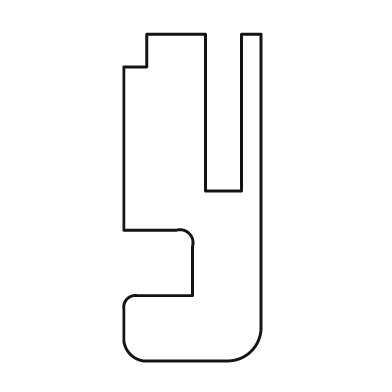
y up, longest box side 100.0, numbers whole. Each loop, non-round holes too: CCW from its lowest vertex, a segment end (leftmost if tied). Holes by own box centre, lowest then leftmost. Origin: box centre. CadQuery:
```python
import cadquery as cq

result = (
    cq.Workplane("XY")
    .moveTo(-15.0, -50.0)
    .lineTo(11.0, -50.0)
    .threePointArc((18.0, -47.0), (21.0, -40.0))
    .lineTo(21.0, 50.0)
    .lineTo(15.0, 50.0)
    .lineTo(15.0, 2.0)
    .lineTo(4.0, 2.0)
    .lineTo(4.0, 50.0)
    .lineTo(-14.0, 50.0)
    .lineTo(-14.0, 40.0)
    .lineTo(-21.0, 40.0)
    .lineTo(-21.0, -10.0)
    .lineTo(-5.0, -10.0)
    .threePointArc((-1.0, -11.0), (0.0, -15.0))
    .lineTo(0.0, -30.0)
    .lineTo(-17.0, -30.0)
    .threePointArc((-20.0, -31.0), (-21.0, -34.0))
    .lineTo(-21.0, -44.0)
    .threePointArc((-19.0, -48.0), (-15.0, -50.0))
    .close()
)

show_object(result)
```